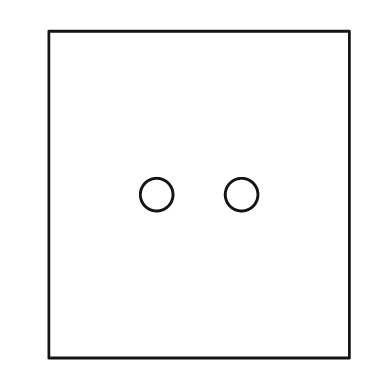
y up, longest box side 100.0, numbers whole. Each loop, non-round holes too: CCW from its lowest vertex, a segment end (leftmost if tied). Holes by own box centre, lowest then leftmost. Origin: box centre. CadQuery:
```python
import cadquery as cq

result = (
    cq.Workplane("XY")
    .moveTo(-46.0, -50.0)
    .lineTo(46.0, -50.0)
    .lineTo(46.0, 50.0)
    .lineTo(-46.0, 50.0)
    .close()
    .moveTo(-13.0, 0.0)
    .circle(5.0)
    .moveTo(13.0, 0.0)
    .circle(5.0)
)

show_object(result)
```